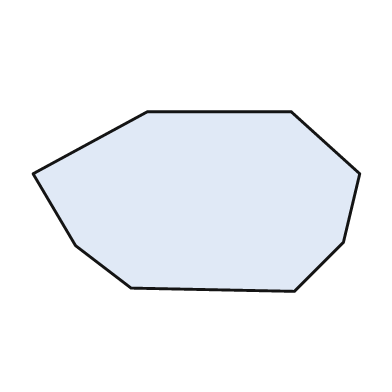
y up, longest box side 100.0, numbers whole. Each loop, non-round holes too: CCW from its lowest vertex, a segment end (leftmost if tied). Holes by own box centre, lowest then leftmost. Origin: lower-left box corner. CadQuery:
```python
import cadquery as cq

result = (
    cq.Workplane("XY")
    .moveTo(80.0, 0.0)
    .lineTo(95.0, 15.0)
    .lineTo(100.0, 36.0)
    .lineTo(79.0, 55.0)
    .lineTo(35.0, 55.0)
    .lineTo(0.0, 36.0)
    .lineTo(13.0, 14.0)
    .lineTo(30.0, 1.0)
    .close()
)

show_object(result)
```